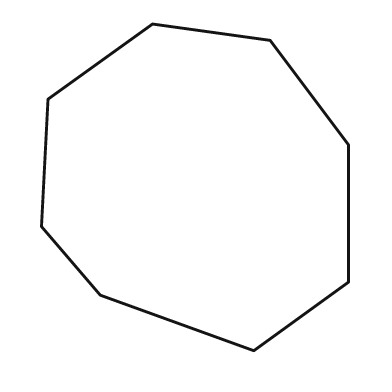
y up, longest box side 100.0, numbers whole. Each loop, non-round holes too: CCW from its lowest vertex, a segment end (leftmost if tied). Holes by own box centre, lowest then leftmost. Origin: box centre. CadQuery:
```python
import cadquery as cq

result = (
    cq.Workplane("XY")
    .moveTo(18.0, -50.0)
    .lineTo(47.0, -29.0)
    .lineTo(47.0, 13.0)
    .lineTo(23.0, 45.0)
    .lineTo(-13.0, 50.0)
    .lineTo(-45.0, 27.0)
    .lineTo(-47.0, -12.0)
    .lineTo(-29.0, -33.0)
    .close()
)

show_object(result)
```